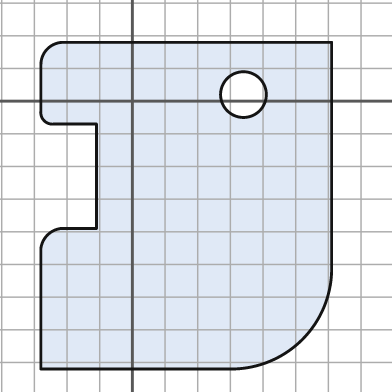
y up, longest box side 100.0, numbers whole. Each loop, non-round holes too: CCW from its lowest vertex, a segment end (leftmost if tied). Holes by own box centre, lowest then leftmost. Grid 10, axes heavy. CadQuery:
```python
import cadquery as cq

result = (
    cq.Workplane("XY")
    .moveTo(-28.0, -82.0)
    .lineTo(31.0, -82.0)
    .threePointArc((52.0, -73.0), (61.0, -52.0))
    .lineTo(61.0, 18.0)
    .lineTo(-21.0, 18.0)
    .threePointArc((-26.0, 16.0), (-28.0, 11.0))
    .lineTo(-28.0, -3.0)
    .threePointArc((-27.0, -6.0), (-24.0, -7.0))
    .lineTo(-11.0, -7.0)
    .lineTo(-11.0, -39.0)
    .lineTo(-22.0, -39.0)
    .threePointArc((-26.0, -41.0), (-28.0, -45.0))
    .close()
    .moveTo(34.0, 2.0)
    .circle(7.0)
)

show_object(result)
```